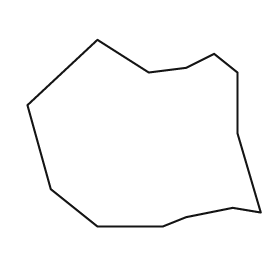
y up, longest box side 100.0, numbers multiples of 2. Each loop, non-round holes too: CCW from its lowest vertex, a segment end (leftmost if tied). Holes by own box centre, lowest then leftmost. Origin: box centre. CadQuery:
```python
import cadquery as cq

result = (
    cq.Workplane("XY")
    .moveTo(-20.0, -40.0)
    .lineTo(8.0, -40.0)
    .lineTo(18.0, -36.0)
    .lineTo(38.0, -32.0)
    .lineTo(50.0, -34.0)
    .lineTo(40.0, 0.0)
    .lineTo(40.0, 26.0)
    .lineTo(30.0, 34.0)
    .lineTo(18.0, 28.0)
    .lineTo(2.0, 26.0)
    .lineTo(-20.0, 40.0)
    .lineTo(-50.0, 12.0)
    .lineTo(-40.0, -24.0)
    .close()
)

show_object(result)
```